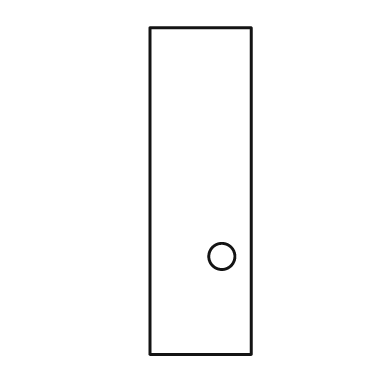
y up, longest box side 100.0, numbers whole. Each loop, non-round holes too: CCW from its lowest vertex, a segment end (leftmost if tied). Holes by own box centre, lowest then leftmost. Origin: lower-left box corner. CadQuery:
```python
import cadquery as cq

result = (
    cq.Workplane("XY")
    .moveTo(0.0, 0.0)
    .lineTo(31.0, 0.0)
    .lineTo(31.0, 100.0)
    .lineTo(0.0, 100.0)
    .close()
    .moveTo(22.0, 30.0)
    .circle(4.0)
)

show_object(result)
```